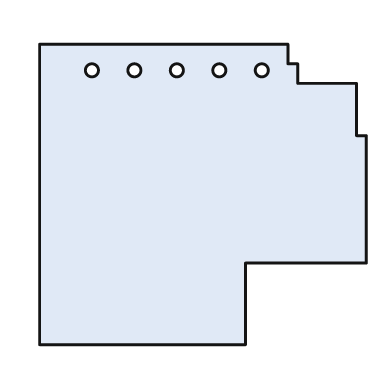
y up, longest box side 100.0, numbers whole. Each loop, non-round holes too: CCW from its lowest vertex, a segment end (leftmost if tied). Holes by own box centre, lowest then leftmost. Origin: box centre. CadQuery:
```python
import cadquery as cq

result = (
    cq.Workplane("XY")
    .moveTo(-50.0, -46.0)
    .lineTo(13.0, -46.0)
    .lineTo(13.0, -21.0)
    .lineTo(50.0, -21.0)
    .lineTo(50.0, 18.0)
    .lineTo(47.0, 18.0)
    .lineTo(47.0, 34.0)
    .lineTo(29.0, 34.0)
    .lineTo(29.0, 40.0)
    .lineTo(26.0, 40.0)
    .lineTo(26.0, 46.0)
    .lineTo(-50.0, 46.0)
    .close()
    .moveTo(-34.0, 38.0)
    .circle(2.0)
    .moveTo(-21.0, 38.0)
    .circle(2.0)
    .moveTo(-8.0, 38.0)
    .circle(2.0)
    .moveTo(5.0, 38.0)
    .circle(2.0)
    .moveTo(18.0, 38.0)
    .circle(2.0)
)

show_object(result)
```